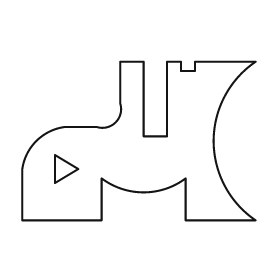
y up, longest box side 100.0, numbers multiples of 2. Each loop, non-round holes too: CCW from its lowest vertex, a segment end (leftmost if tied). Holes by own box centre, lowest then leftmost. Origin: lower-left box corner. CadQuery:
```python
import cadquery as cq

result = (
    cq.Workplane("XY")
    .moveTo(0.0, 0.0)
    .lineTo(34.0, 0.0)
    .lineTo(34.0, 18.0)
    .threePointArc((52.0, 12.0), (70.0, 18.0))
    .lineTo(70.0, 0.0)
    .lineTo(100.0, 0.0)
    .threePointArc((82.0, 34.0), (100.0, 68.0))
    .lineTo(74.0, 68.0)
    .lineTo(74.0, 64.0)
    .lineTo(68.0, 64.0)
    .lineTo(68.0, 68.0)
    .lineTo(62.0, 68.0)
    .lineTo(62.0, 36.0)
    .lineTo(52.0, 36.0)
    .lineTo(52.0, 68.0)
    .lineTo(42.0, 68.0)
    .lineTo(42.0, 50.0)
    .threePointArc((40.0, 42.0), (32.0, 40.0))
    .lineTo(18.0, 40.0)
    .threePointArc((6.0, 34.0), (0.0, 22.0))
    .close()
    .moveTo(14.0, 16.0)
    .lineTo(24.0, 22.0)
    .lineTo(14.0, 28.0)
    .close()
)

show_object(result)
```